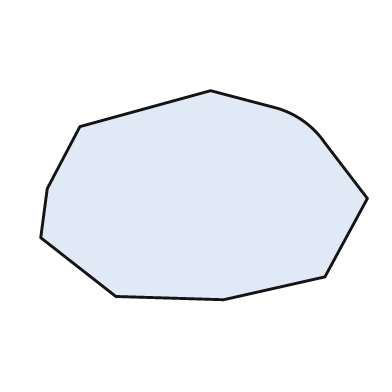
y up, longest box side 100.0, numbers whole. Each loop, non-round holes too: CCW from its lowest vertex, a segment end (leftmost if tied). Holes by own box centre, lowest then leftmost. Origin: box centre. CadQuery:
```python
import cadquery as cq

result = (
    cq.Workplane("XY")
    .moveTo(6.0, -32.0)
    .lineTo(37.0, -25.0)
    .lineTo(50.0, -1.0)
    .lineTo(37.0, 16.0)
    .threePointArc((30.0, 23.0), (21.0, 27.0))
    .lineTo(2.0, 32.0)
    .lineTo(-38.0, 21.0)
    .lineTo(-48.0, 2.0)
    .lineTo(-50.0, -13.0)
    .lineTo(-27.0, -31.0)
    .close()
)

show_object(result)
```